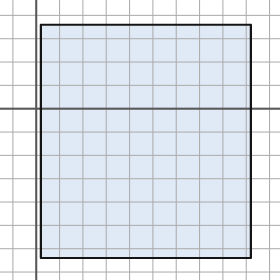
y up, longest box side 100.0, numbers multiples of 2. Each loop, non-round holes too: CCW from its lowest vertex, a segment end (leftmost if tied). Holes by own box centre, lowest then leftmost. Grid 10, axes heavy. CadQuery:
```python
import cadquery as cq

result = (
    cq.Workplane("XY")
    .moveTo(2.0, -64.0)
    .lineTo(92.0, -64.0)
    .lineTo(92.0, 36.0)
    .lineTo(2.0, 36.0)
    .close()
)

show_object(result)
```